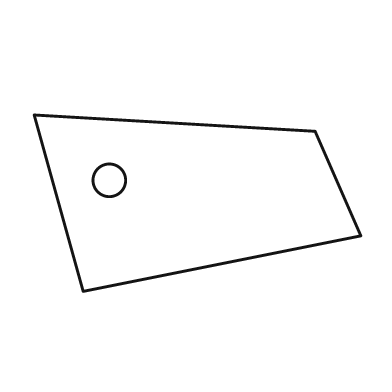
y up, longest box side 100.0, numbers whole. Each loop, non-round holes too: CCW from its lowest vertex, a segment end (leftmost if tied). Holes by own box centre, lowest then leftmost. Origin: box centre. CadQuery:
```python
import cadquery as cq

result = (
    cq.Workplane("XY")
    .moveTo(-35.0, -27.0)
    .lineTo(50.0, -10.0)
    .lineTo(36.0, 22.0)
    .lineTo(-50.0, 27.0)
    .close()
    .moveTo(-27.0, 7.0)
    .circle(5.0)
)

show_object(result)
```